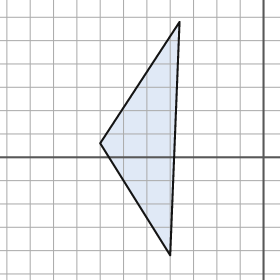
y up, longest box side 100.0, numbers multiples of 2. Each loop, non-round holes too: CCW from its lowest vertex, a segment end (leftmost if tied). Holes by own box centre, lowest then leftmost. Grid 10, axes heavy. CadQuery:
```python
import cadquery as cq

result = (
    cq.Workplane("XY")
    .moveTo(-40.0, -42.0)
    .lineTo(-36.0, 58.0)
    .lineTo(-70.0, 6.0)
    .close()
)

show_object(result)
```